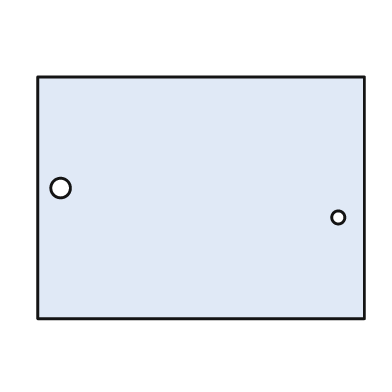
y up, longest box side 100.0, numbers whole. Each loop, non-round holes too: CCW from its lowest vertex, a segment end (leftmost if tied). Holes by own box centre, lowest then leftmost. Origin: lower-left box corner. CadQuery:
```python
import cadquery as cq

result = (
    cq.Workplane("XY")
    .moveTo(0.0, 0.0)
    .lineTo(100.0, 0.0)
    .lineTo(100.0, 74.0)
    .lineTo(0.0, 74.0)
    .close()
    .moveTo(92.0, 31.0)
    .circle(2.0)
    .moveTo(7.0, 40.0)
    .circle(3.0)
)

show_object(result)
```